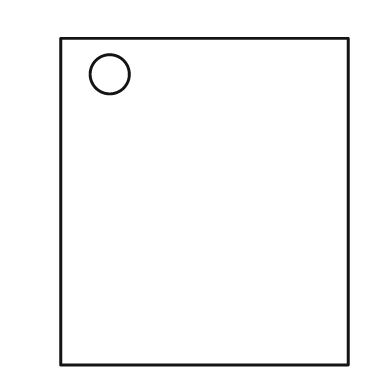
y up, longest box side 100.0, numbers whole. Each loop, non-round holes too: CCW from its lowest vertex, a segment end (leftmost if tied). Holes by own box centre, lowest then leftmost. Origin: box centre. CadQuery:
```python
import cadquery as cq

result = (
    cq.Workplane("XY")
    .moveTo(-44.0, -50.0)
    .lineTo(44.0, -50.0)
    .lineTo(44.0, 50.0)
    .lineTo(-44.0, 50.0)
    .close()
    .moveTo(-29.0, 39.0)
    .circle(6.0)
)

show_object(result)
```